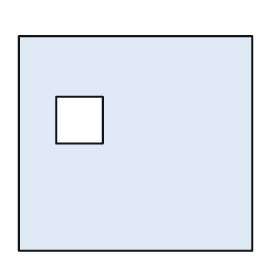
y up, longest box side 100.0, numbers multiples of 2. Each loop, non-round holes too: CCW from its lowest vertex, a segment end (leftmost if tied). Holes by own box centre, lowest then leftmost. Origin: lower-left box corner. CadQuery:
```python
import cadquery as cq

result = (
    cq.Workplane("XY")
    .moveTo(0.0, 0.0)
    .lineTo(100.0, 0.0)
    .lineTo(100.0, 92.0)
    .lineTo(0.0, 92.0)
    .close()
    .moveTo(16.0, 46.0)
    .lineTo(36.0, 46.0)
    .lineTo(36.0, 66.0)
    .lineTo(16.0, 66.0)
    .close()
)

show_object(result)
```